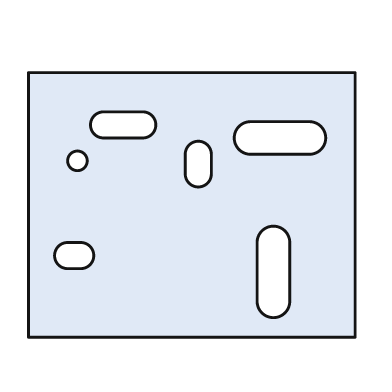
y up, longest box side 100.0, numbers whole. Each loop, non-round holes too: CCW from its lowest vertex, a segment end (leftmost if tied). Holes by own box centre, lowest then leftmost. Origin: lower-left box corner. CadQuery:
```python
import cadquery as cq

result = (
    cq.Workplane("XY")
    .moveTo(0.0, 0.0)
    .lineTo(100.0, 0.0)
    .lineTo(100.0, 81.0)
    .lineTo(0.0, 81.0)
    .close()
    .moveTo(70.0, 11.0)
    .threePointArc((75.0, 6.0), (80.0, 11.0))
    .lineTo(80.0, 29.0)
    .threePointArc((75.0, 34.0), (70.0, 29.0))
    .close()
    .moveTo(12.0, 21.0)
    .lineTo(16.0, 21.0)
    .threePointArc((20.0, 25.0), (16.0, 29.0))
    .lineTo(12.0, 29.0)
    .threePointArc((8.0, 25.0), (12.0, 21.0))
    .close()
    .moveTo(48.0, 50.0)
    .threePointArc((52.0, 46.0), (56.0, 50.0))
    .lineTo(56.0, 56.0)
    .threePointArc((52.0, 60.0), (48.0, 56.0))
    .close()
    .moveTo(15.0, 54.0)
    .circle(3.0)
    .moveTo(68.0, 56.0)
    .lineTo(86.0, 56.0)
    .threePointArc((91.0, 61.0), (86.0, 66.0))
    .lineTo(68.0, 66.0)
    .threePointArc((63.0, 61.0), (68.0, 56.0))
    .close()
    .moveTo(23.0, 61.0)
    .lineTo(35.0, 61.0)
    .threePointArc((39.0, 65.0), (35.0, 69.0))
    .lineTo(23.0, 69.0)
    .threePointArc((19.0, 65.0), (23.0, 61.0))
    .close()
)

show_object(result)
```